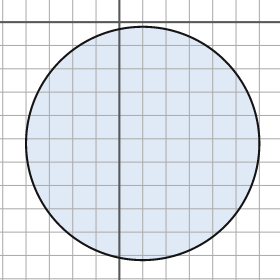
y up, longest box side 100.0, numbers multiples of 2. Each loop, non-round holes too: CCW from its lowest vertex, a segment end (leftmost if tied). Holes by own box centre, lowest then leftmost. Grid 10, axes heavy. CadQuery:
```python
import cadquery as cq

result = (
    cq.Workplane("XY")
    .moveTo(10.0, -52.0)
    .circle(50.0)
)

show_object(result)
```